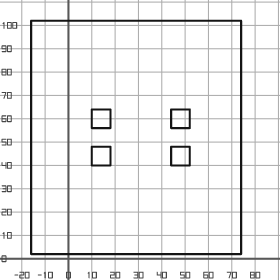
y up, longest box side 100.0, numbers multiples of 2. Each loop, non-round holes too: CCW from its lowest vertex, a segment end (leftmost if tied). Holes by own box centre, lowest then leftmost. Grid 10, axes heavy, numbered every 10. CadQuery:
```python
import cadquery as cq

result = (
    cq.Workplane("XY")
    .moveTo(-16.0, 2.0)
    .lineTo(74.0, 2.0)
    .lineTo(74.0, 102.0)
    .lineTo(-16.0, 102.0)
    .close()
    .moveTo(10.0, 40.0)
    .lineTo(18.0, 40.0)
    .lineTo(18.0, 48.0)
    .lineTo(10.0, 48.0)
    .close()
    .moveTo(44.0, 40.0)
    .lineTo(52.0, 40.0)
    .lineTo(52.0, 48.0)
    .lineTo(44.0, 48.0)
    .close()
    .moveTo(10.0, 56.0)
    .lineTo(18.0, 56.0)
    .lineTo(18.0, 64.0)
    .lineTo(10.0, 64.0)
    .close()
    .moveTo(44.0, 56.0)
    .lineTo(52.0, 56.0)
    .lineTo(52.0, 64.0)
    .lineTo(44.0, 64.0)
    .close()
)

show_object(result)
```